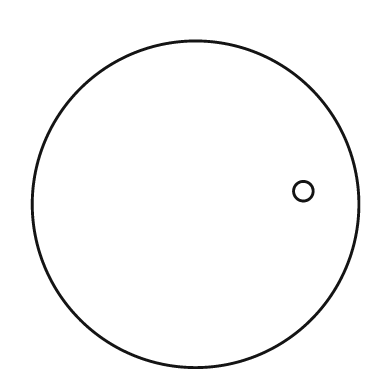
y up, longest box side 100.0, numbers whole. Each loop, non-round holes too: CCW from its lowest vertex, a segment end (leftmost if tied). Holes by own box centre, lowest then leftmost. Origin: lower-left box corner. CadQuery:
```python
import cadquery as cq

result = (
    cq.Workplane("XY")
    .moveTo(50.0, 50.0)
    .circle(50.0)
    .moveTo(83.0, 54.0)
    .circle(3.0)
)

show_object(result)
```